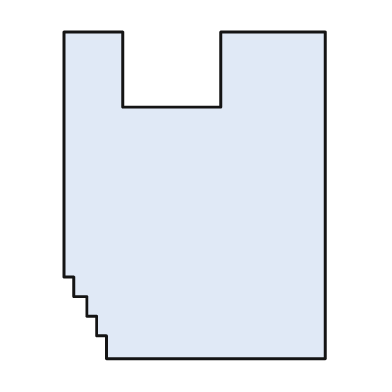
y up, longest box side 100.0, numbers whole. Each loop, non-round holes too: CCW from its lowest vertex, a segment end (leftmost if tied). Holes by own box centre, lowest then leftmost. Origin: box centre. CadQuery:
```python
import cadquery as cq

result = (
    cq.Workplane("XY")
    .moveTo(-27.0, -50.0)
    .lineTo(40.0, -50.0)
    .lineTo(40.0, 50.0)
    .lineTo(8.0, 50.0)
    .lineTo(8.0, 27.0)
    .lineTo(-22.0, 27.0)
    .lineTo(-22.0, 50.0)
    .lineTo(-40.0, 50.0)
    .lineTo(-40.0, -25.0)
    .lineTo(-37.0, -25.0)
    .lineTo(-37.0, -31.0)
    .lineTo(-33.0, -31.0)
    .lineTo(-33.0, -37.0)
    .lineTo(-30.0, -37.0)
    .lineTo(-30.0, -43.0)
    .lineTo(-27.0, -43.0)
    .close()
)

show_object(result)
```